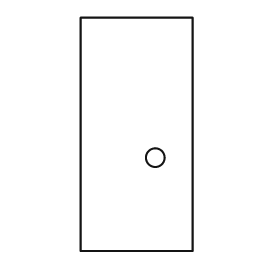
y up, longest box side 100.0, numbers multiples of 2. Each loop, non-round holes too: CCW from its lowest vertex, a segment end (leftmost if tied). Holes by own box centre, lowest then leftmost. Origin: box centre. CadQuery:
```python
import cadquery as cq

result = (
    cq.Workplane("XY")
    .moveTo(-24.0, -50.0)
    .lineTo(24.0, -50.0)
    .lineTo(24.0, 50.0)
    .lineTo(-24.0, 50.0)
    .close()
    .moveTo(8.0, -10.0)
    .circle(4.0)
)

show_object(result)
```